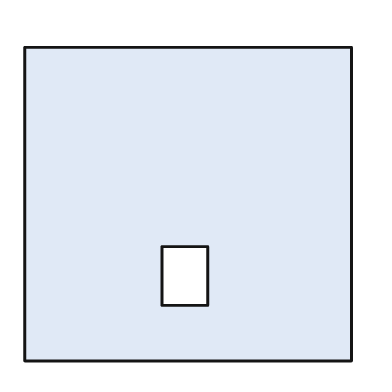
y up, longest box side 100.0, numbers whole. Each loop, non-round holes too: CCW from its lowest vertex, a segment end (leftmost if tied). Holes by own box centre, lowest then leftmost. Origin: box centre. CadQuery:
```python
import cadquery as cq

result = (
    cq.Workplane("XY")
    .moveTo(-50.0, -48.0)
    .lineTo(50.0, -48.0)
    .lineTo(50.0, 48.0)
    .lineTo(-50.0, 48.0)
    .close()
    .moveTo(-8.0, -31.0)
    .lineTo(6.0, -31.0)
    .lineTo(6.0, -13.0)
    .lineTo(-8.0, -13.0)
    .close()
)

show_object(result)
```